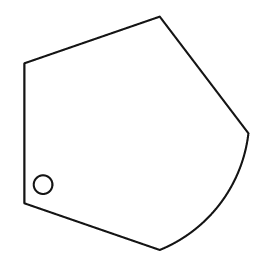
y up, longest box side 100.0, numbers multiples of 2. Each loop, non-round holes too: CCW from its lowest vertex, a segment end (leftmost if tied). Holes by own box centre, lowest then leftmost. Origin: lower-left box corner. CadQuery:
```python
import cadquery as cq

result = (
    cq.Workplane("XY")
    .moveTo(58.0, 0.0)
    .threePointArc((84.0, 20.0), (96.0, 50.0))
    .lineTo(58.0, 100.0)
    .lineTo(0.0, 80.0)
    .lineTo(0.0, 20.0)
    .close()
    .moveTo(8.0, 28.0)
    .circle(4.0)
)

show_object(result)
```